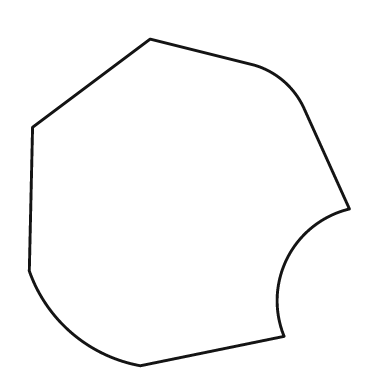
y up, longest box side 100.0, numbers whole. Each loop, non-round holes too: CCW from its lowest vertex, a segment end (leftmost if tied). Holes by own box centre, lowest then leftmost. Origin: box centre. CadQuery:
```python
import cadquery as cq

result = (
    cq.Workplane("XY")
    .moveTo(-15.0, -50.0)
    .lineTo(29.0, -41.0)
    .threePointArc((30.0, -17.0), (49.0, -2.0))
    .lineTo(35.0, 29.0)
    .threePointArc((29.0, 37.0), (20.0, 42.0))
    .lineTo(-12.0, 50.0)
    .lineTo(-48.0, 23.0)
    .lineTo(-49.0, -21.0)
    .threePointArc((-36.0, -40.0), (-15.0, -50.0))
    .close()
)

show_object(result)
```